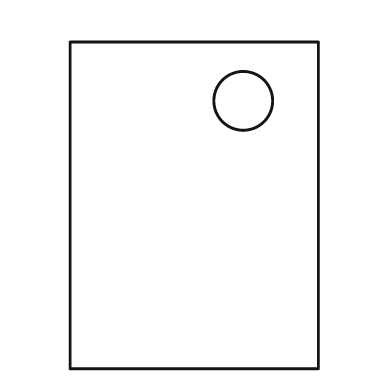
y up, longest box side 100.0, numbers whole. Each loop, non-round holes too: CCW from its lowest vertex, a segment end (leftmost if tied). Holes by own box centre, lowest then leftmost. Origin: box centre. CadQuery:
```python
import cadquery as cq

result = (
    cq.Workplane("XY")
    .moveTo(-38.0, -50.0)
    .lineTo(38.0, -50.0)
    .lineTo(38.0, 50.0)
    .lineTo(-38.0, 50.0)
    .close()
    .moveTo(15.0, 32.0)
    .circle(9.0)
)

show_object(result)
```